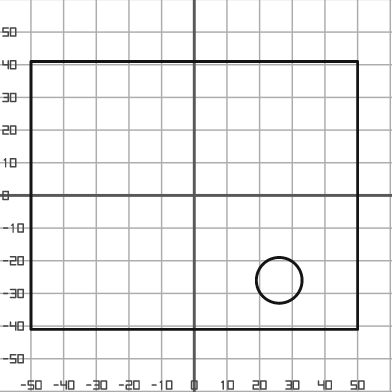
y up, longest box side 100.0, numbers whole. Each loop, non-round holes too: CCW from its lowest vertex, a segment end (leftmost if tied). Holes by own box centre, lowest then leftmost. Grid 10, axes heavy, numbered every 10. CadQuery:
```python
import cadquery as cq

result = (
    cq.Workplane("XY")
    .moveTo(-50.0, -41.0)
    .lineTo(50.0, -41.0)
    .lineTo(50.0, 41.0)
    .lineTo(-50.0, 41.0)
    .close()
    .moveTo(26.0, -26.0)
    .circle(7.0)
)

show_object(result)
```